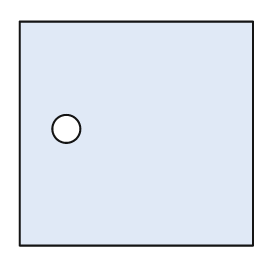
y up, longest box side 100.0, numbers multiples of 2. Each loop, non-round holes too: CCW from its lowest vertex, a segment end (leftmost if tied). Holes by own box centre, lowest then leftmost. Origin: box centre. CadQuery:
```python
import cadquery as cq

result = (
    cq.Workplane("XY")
    .moveTo(-50.0, -48.0)
    .lineTo(50.0, -48.0)
    .lineTo(50.0, 48.0)
    .lineTo(-50.0, 48.0)
    .close()
    .moveTo(-30.0, 2.0)
    .circle(6.0)
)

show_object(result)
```